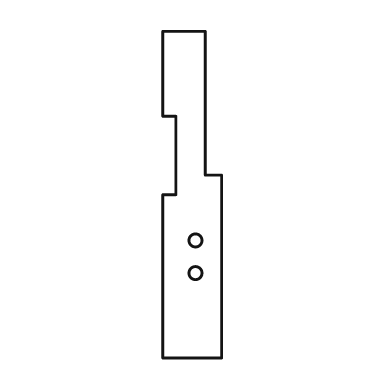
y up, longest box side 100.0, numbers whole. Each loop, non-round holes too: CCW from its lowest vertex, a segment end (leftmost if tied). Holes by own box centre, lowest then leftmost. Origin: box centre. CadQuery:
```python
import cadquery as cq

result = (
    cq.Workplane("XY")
    .moveTo(-9.0, -50.0)
    .lineTo(9.0, -50.0)
    .lineTo(9.0, 6.0)
    .lineTo(4.0, 6.0)
    .lineTo(4.0, 50.0)
    .lineTo(-9.0, 50.0)
    .lineTo(-9.0, 24.0)
    .lineTo(-5.0, 24.0)
    .lineTo(-5.0, 0.0)
    .lineTo(-9.0, 0.0)
    .close()
    .moveTo(1.0, -24.0)
    .circle(2.0)
    .moveTo(1.0, -14.0)
    .circle(2.0)
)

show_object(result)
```